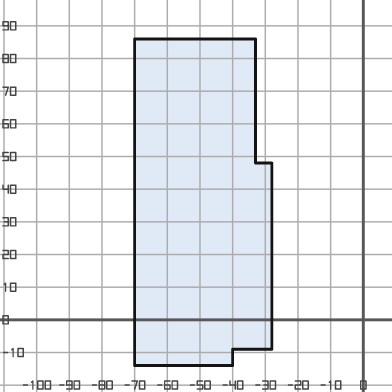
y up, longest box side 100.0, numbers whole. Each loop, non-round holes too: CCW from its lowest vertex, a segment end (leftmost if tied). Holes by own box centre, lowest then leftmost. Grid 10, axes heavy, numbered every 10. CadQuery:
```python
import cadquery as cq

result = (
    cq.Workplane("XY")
    .moveTo(-70.0, -14.0)
    .lineTo(-40.0, -14.0)
    .lineTo(-40.0, -9.0)
    .lineTo(-28.0, -9.0)
    .lineTo(-28.0, 48.0)
    .lineTo(-33.0, 48.0)
    .lineTo(-33.0, 86.0)
    .lineTo(-70.0, 86.0)
    .close()
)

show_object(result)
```